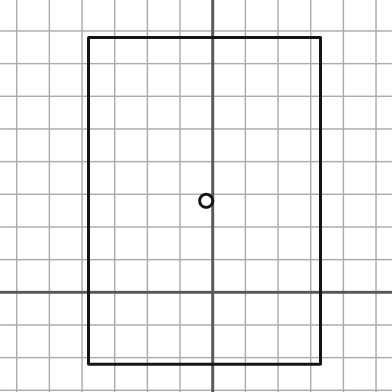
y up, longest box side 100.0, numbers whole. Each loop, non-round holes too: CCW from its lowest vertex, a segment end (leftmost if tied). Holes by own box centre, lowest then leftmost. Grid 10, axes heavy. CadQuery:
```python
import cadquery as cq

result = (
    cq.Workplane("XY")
    .moveTo(-38.0, -22.0)
    .lineTo(33.0, -22.0)
    .lineTo(33.0, 78.0)
    .lineTo(-38.0, 78.0)
    .close()
    .moveTo(-2.0, 28.0)
    .circle(2.0)
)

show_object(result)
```